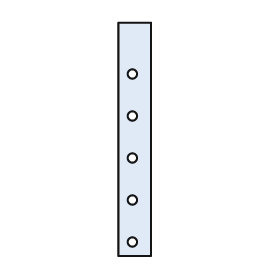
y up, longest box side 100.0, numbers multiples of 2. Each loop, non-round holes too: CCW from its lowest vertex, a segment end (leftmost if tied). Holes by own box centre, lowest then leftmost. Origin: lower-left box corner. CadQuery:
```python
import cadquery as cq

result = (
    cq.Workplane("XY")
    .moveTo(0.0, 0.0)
    .lineTo(14.0, 0.0)
    .lineTo(14.0, 100.0)
    .lineTo(0.0, 100.0)
    .close()
    .moveTo(6.0, 6.0)
    .circle(2.0)
    .moveTo(6.0, 24.0)
    .circle(2.0)
    .moveTo(6.0, 42.0)
    .circle(2.0)
    .moveTo(6.0, 60.0)
    .circle(2.0)
    .moveTo(6.0, 78.0)
    .circle(2.0)
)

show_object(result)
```